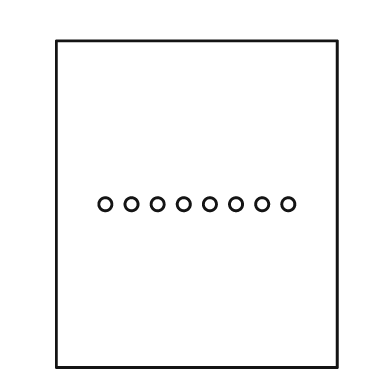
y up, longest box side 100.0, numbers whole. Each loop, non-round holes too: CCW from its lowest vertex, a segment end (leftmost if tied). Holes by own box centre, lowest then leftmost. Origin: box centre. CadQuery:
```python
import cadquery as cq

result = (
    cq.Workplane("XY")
    .moveTo(-43.0, -50.0)
    .lineTo(43.0, -50.0)
    .lineTo(43.0, 50.0)
    .lineTo(-43.0, 50.0)
    .close()
    .moveTo(-28.0, 0.0)
    .circle(2.0)
    .moveTo(-20.0, 0.0)
    .circle(2.0)
    .moveTo(-12.0, 0.0)
    .circle(2.0)
    .moveTo(-4.0, 0.0)
    .circle(2.0)
    .moveTo(4.0, 0.0)
    .circle(2.0)
    .moveTo(12.0, 0.0)
    .circle(2.0)
    .moveTo(20.0, 0.0)
    .circle(2.0)
    .moveTo(28.0, 0.0)
    .circle(2.0)
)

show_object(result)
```